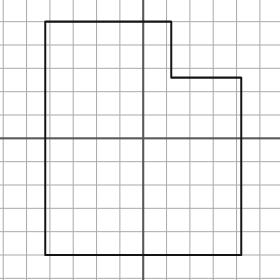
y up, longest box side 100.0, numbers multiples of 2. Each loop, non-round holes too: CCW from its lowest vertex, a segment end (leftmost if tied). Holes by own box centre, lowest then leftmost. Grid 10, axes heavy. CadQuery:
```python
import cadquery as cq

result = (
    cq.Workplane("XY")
    .moveTo(-42.0, -50.0)
    .lineTo(42.0, -50.0)
    .lineTo(42.0, 26.0)
    .lineTo(12.0, 26.0)
    .lineTo(12.0, 50.0)
    .lineTo(-42.0, 50.0)
    .close()
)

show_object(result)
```